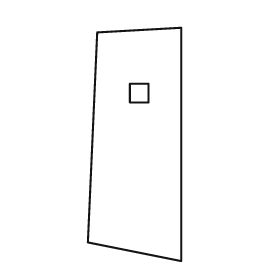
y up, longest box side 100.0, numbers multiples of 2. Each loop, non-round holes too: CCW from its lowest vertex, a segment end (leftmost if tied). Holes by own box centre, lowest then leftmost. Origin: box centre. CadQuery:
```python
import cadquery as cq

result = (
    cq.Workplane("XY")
    .moveTo(20.0, -50.0)
    .lineTo(20.0, 50.0)
    .lineTo(-16.0, 48.0)
    .lineTo(-20.0, -42.0)
    .close()
    .moveTo(-2.0, 18.0)
    .lineTo(6.0, 18.0)
    .lineTo(6.0, 26.0)
    .lineTo(-2.0, 26.0)
    .close()
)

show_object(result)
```